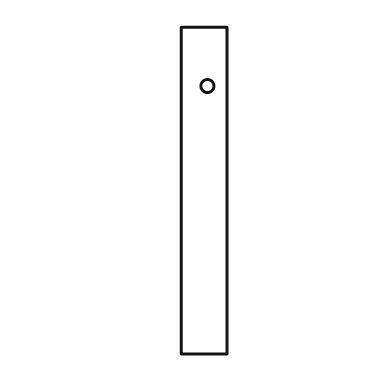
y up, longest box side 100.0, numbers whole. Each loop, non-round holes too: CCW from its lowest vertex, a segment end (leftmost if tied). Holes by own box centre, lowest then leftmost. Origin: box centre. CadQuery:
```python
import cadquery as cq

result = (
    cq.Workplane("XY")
    .moveTo(-7.0, -50.0)
    .lineTo(7.0, -50.0)
    .lineTo(7.0, 50.0)
    .lineTo(-7.0, 50.0)
    .close()
    .moveTo(1.0, 32.0)
    .circle(2.0)
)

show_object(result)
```